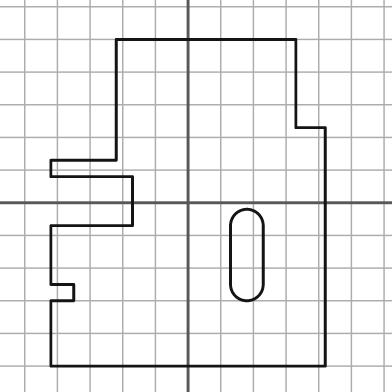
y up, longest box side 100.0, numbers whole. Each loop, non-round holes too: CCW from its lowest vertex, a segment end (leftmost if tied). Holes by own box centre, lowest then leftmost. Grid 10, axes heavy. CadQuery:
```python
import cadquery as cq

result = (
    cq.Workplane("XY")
    .moveTo(-42.0, -50.0)
    .lineTo(42.0, -50.0)
    .lineTo(42.0, 23.0)
    .lineTo(33.0, 23.0)
    .lineTo(33.0, 50.0)
    .lineTo(-22.0, 50.0)
    .lineTo(-22.0, 13.0)
    .lineTo(-42.0, 13.0)
    .lineTo(-42.0, 8.0)
    .lineTo(-17.0, 8.0)
    .lineTo(-17.0, -7.0)
    .lineTo(-42.0, -7.0)
    .lineTo(-42.0, -25.0)
    .lineTo(-35.0, -25.0)
    .lineTo(-35.0, -30.0)
    .lineTo(-42.0, -30.0)
    .close()
    .moveTo(13.0, -25.0)
    .threePointArc((18.0, -30.0), (23.0, -25.0))
    .lineTo(23.0, -7.0)
    .threePointArc((18.0, -2.0), (13.0, -7.0))
    .close()
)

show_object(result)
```